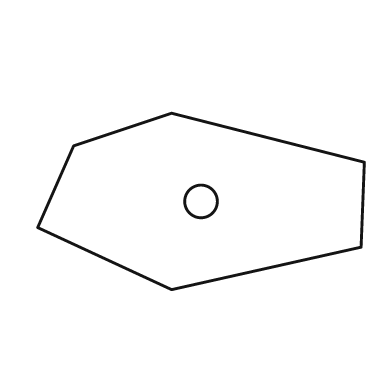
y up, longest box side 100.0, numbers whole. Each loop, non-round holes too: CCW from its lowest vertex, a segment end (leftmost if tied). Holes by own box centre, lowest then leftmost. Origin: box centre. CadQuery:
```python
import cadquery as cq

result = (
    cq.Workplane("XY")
    .moveTo(-9.0, -27.0)
    .lineTo(49.0, -14.0)
    .lineTo(50.0, 12.0)
    .lineTo(-9.0, 27.0)
    .lineTo(-39.0, 17.0)
    .lineTo(-50.0, -8.0)
    .close()
    .moveTo(0.0, 0.0)
    .circle(5.0)
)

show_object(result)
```